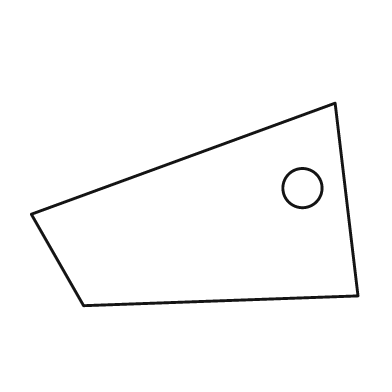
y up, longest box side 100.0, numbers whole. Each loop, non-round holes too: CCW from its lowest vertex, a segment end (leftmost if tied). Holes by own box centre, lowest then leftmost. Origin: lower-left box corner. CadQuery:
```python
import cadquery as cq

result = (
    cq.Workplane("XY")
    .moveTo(16.0, 0.0)
    .lineTo(100.0, 3.0)
    .lineTo(93.0, 62.0)
    .lineTo(0.0, 28.0)
    .close()
    .moveTo(83.0, 36.0)
    .circle(6.0)
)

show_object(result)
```